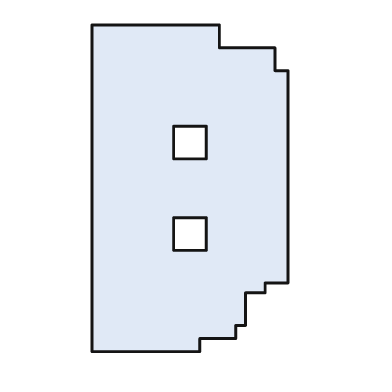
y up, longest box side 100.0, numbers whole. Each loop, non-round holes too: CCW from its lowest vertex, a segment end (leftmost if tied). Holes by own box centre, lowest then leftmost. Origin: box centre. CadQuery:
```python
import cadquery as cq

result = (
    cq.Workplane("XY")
    .moveTo(-30.0, -50.0)
    .lineTo(3.0, -50.0)
    .lineTo(3.0, -46.0)
    .lineTo(14.0, -46.0)
    .lineTo(14.0, -42.0)
    .lineTo(17.0, -42.0)
    .lineTo(17.0, -32.0)
    .lineTo(23.0, -32.0)
    .lineTo(23.0, -29.0)
    .lineTo(30.0, -29.0)
    .lineTo(30.0, 36.0)
    .lineTo(26.0, 36.0)
    .lineTo(26.0, 43.0)
    .lineTo(9.0, 43.0)
    .lineTo(9.0, 50.0)
    .lineTo(-30.0, 50.0)
    .close()
    .moveTo(-5.0, -19.0)
    .lineTo(5.0, -19.0)
    .lineTo(5.0, -9.0)
    .lineTo(-5.0, -9.0)
    .close()
    .moveTo(-5.0, 9.0)
    .lineTo(5.0, 9.0)
    .lineTo(5.0, 19.0)
    .lineTo(-5.0, 19.0)
    .close()
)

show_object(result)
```